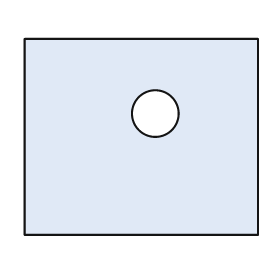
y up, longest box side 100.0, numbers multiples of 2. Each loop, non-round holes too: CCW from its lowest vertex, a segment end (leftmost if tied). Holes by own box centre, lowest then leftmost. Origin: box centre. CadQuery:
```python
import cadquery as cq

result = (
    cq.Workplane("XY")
    .moveTo(-50.0, -42.0)
    .lineTo(50.0, -42.0)
    .lineTo(50.0, 42.0)
    .lineTo(-50.0, 42.0)
    .close()
    .moveTo(6.0, 10.0)
    .circle(10.0)
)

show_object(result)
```